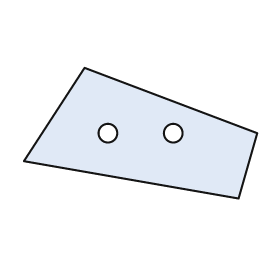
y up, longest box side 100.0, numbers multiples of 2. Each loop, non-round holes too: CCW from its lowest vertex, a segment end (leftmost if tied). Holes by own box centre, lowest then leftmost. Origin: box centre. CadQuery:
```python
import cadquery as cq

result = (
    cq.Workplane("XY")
    .moveTo(42.0, -28.0)
    .lineTo(50.0, 0.0)
    .lineTo(-24.0, 28.0)
    .lineTo(-50.0, -12.0)
    .close()
    .moveTo(-14.0, 0.0)
    .circle(4.0)
    .moveTo(14.0, 0.0)
    .circle(4.0)
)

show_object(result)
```